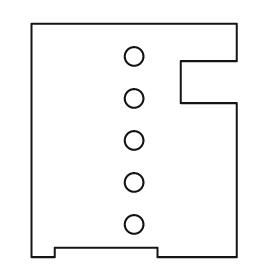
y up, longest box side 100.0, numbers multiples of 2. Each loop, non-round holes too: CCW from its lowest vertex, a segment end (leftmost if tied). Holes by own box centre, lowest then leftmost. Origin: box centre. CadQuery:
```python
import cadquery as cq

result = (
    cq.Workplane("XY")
    .moveTo(-44.0, -50.0)
    .lineTo(-34.0, -50.0)
    .lineTo(-34.0, -46.0)
    .lineTo(10.0, -46.0)
    .lineTo(10.0, -50.0)
    .lineTo(44.0, -50.0)
    .lineTo(44.0, 16.0)
    .lineTo(20.0, 16.0)
    .lineTo(20.0, 34.0)
    .lineTo(44.0, 34.0)
    .lineTo(44.0, 50.0)
    .lineTo(-44.0, 50.0)
    .close()
    .moveTo(0.0, -36.0)
    .circle(4.0)
    .moveTo(0.0, -18.0)
    .circle(4.0)
    .moveTo(0.0, 0.0)
    .circle(4.0)
    .moveTo(0.0, 18.0)
    .circle(4.0)
    .moveTo(0.0, 36.0)
    .circle(4.0)
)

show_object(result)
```